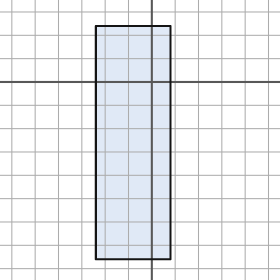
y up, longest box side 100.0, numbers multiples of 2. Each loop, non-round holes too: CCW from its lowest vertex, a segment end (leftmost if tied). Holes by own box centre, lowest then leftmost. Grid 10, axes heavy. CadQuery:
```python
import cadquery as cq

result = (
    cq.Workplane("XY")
    .moveTo(-24.0, -76.0)
    .lineTo(8.0, -76.0)
    .lineTo(8.0, 24.0)
    .lineTo(-24.0, 24.0)
    .close()
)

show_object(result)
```